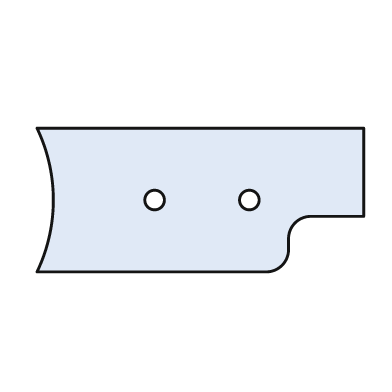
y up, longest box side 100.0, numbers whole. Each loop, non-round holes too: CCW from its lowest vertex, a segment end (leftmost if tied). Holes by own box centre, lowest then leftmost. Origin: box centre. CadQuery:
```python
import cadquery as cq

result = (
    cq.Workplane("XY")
    .moveTo(-50.0, -22.0)
    .lineTo(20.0, -22.0)
    .threePointArc((25.0, -20.0), (27.0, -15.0))
    .lineTo(27.0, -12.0)
    .threePointArc((29.0, -7.0), (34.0, -5.0))
    .lineTo(50.0, -5.0)
    .lineTo(50.0, 22.0)
    .lineTo(-50.0, 22.0)
    .threePointArc((-45.0, 0.0), (-50.0, -22.0))
    .close()
    .moveTo(-14.0, 0.0)
    .circle(3.0)
    .moveTo(15.0, 0.0)
    .circle(3.0)
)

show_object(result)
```